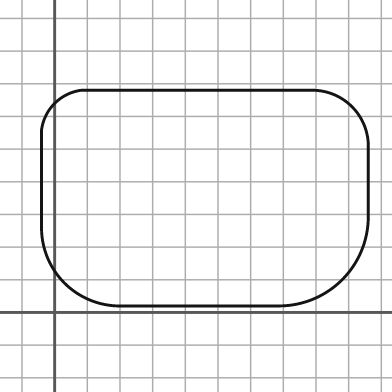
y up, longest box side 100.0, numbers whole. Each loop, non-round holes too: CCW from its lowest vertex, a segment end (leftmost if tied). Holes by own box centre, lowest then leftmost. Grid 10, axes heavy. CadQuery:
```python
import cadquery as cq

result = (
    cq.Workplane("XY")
    .moveTo(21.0, 2.0)
    .lineTo(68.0, 2.0)
    .threePointArc((88.0, 10.0), (96.0, 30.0))
    .lineTo(96.0, 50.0)
    .threePointArc((91.0, 63.0), (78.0, 68.0))
    .lineTo(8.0, 68.0)
    .threePointArc((0.0, 64.0), (-4.0, 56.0))
    .lineTo(-4.0, 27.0)
    .threePointArc((3.0, 9.0), (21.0, 2.0))
    .close()
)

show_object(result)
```